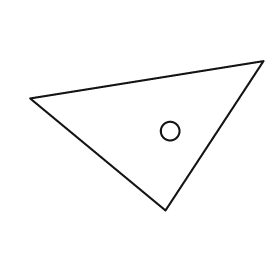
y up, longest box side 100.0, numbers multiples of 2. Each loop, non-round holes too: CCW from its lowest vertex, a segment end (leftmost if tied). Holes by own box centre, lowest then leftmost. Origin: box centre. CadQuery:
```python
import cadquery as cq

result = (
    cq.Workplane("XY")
    .moveTo(8.0, -32.0)
    .lineTo(50.0, 32.0)
    .lineTo(-50.0, 16.0)
    .close()
    .moveTo(10.0, 2.0)
    .circle(4.0)
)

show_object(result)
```